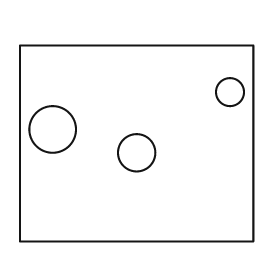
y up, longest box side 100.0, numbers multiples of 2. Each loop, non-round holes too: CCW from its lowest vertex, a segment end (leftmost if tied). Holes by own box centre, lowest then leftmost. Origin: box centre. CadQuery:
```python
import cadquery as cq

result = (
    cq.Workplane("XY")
    .moveTo(-50.0, -42.0)
    .lineTo(50.0, -42.0)
    .lineTo(50.0, 42.0)
    .lineTo(-50.0, 42.0)
    .close()
    .moveTo(0.0, -4.0)
    .circle(8.0)
    .moveTo(-36.0, 6.0)
    .circle(10.0)
    .moveTo(40.0, 22.0)
    .circle(6.0)
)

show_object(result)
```